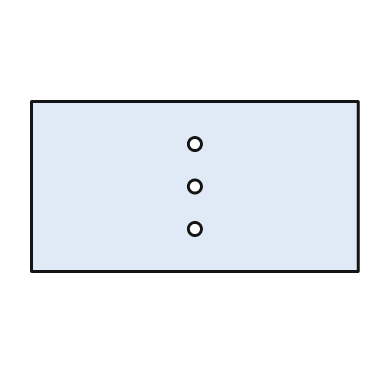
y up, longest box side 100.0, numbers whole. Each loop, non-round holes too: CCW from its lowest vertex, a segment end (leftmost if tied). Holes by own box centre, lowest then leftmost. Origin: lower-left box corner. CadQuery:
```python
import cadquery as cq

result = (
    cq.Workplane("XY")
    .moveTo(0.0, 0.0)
    .lineTo(100.0, 0.0)
    .lineTo(100.0, 52.0)
    .lineTo(0.0, 52.0)
    .close()
    .moveTo(50.0, 13.0)
    .circle(2.0)
    .moveTo(50.0, 26.0)
    .circle(2.0)
    .moveTo(50.0, 39.0)
    .circle(2.0)
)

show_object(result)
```